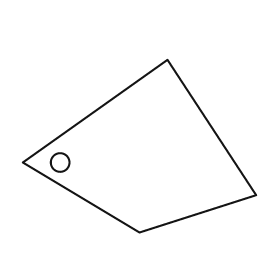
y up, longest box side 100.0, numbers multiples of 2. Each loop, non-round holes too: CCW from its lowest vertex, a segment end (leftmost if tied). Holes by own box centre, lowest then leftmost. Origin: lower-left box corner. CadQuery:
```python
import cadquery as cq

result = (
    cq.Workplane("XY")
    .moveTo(50.0, 0.0)
    .lineTo(100.0, 16.0)
    .lineTo(62.0, 74.0)
    .lineTo(0.0, 30.0)
    .close()
    .moveTo(16.0, 30.0)
    .circle(4.0)
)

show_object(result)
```